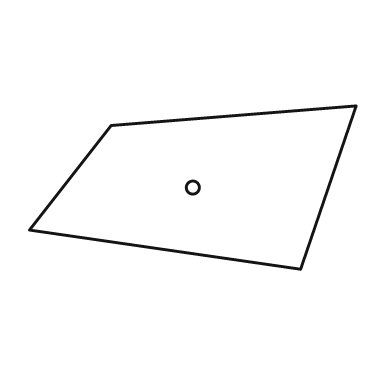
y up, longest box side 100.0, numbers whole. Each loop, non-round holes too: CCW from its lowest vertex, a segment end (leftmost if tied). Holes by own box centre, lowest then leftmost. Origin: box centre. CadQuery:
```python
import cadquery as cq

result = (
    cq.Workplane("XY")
    .moveTo(33.0, -25.0)
    .lineTo(50.0, 25.0)
    .lineTo(-25.0, 19.0)
    .lineTo(-50.0, -13.0)
    .close()
    .moveTo(0.0, 0.0)
    .circle(2.0)
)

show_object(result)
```